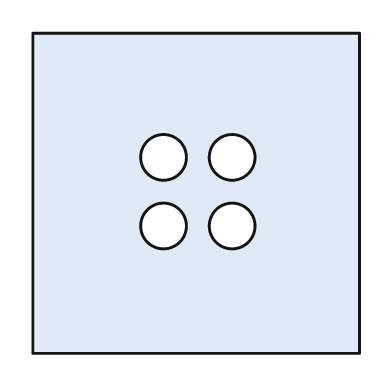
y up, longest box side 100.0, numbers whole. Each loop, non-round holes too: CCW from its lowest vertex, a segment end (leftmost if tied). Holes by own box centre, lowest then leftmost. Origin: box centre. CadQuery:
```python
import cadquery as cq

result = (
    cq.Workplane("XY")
    .moveTo(-50.0, -49.0)
    .lineTo(50.0, -49.0)
    .lineTo(50.0, 49.0)
    .lineTo(-50.0, 49.0)
    .close()
    .moveTo(-10.0, -10.0)
    .circle(7.0)
    .moveTo(11.0, -10.0)
    .circle(7.0)
    .moveTo(-10.0, 11.0)
    .circle(7.0)
    .moveTo(11.0, 11.0)
    .circle(7.0)
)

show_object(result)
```